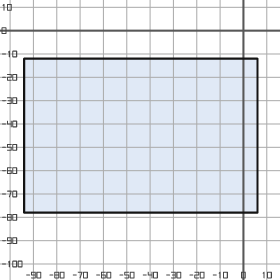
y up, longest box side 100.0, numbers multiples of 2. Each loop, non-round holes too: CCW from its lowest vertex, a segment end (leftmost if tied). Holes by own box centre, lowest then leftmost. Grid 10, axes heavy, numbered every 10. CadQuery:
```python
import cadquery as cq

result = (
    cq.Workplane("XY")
    .moveTo(-94.0, -78.0)
    .lineTo(6.0, -78.0)
    .lineTo(6.0, -12.0)
    .lineTo(-94.0, -12.0)
    .close()
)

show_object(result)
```